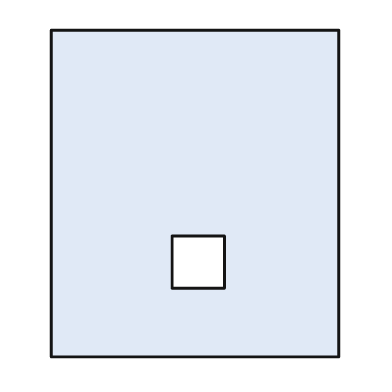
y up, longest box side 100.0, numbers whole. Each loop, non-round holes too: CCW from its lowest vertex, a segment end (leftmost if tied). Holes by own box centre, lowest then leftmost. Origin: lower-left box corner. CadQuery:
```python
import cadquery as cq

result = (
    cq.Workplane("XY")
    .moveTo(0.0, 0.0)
    .lineTo(88.0, 0.0)
    .lineTo(88.0, 100.0)
    .lineTo(0.0, 100.0)
    .close()
    .moveTo(37.0, 21.0)
    .lineTo(53.0, 21.0)
    .lineTo(53.0, 37.0)
    .lineTo(37.0, 37.0)
    .close()
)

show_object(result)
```